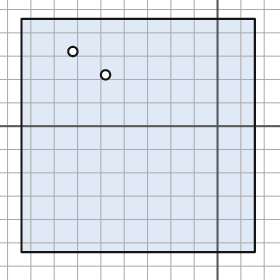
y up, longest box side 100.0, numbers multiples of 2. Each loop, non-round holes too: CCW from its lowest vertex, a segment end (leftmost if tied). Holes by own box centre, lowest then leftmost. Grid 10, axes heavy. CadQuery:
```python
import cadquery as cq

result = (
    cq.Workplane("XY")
    .moveTo(-84.0, -54.0)
    .lineTo(16.0, -54.0)
    .lineTo(16.0, 46.0)
    .lineTo(-84.0, 46.0)
    .close()
    .moveTo(-48.0, 22.0)
    .circle(2.0)
    .moveTo(-62.0, 32.0)
    .circle(2.0)
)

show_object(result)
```